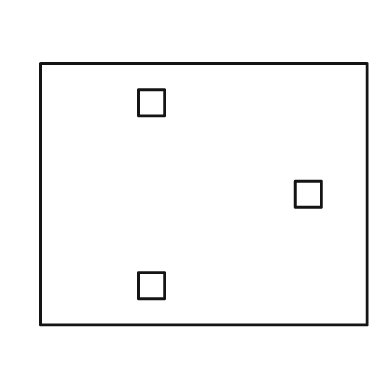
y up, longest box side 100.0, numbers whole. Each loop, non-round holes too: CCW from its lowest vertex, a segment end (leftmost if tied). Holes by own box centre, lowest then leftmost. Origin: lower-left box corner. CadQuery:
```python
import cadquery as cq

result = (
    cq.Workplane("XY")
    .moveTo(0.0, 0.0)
    .lineTo(100.0, 0.0)
    .lineTo(100.0, 80.0)
    .lineTo(0.0, 80.0)
    .close()
    .moveTo(30.0, 8.0)
    .lineTo(38.0, 8.0)
    .lineTo(38.0, 16.0)
    .lineTo(30.0, 16.0)
    .close()
    .moveTo(78.0, 36.0)
    .lineTo(86.0, 36.0)
    .lineTo(86.0, 44.0)
    .lineTo(78.0, 44.0)
    .close()
    .moveTo(30.0, 64.0)
    .lineTo(38.0, 64.0)
    .lineTo(38.0, 72.0)
    .lineTo(30.0, 72.0)
    .close()
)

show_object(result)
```